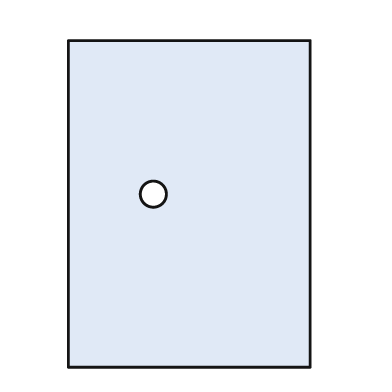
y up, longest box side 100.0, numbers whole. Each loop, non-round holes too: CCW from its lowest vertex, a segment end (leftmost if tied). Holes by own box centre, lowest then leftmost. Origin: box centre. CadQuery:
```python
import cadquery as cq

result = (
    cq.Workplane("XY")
    .moveTo(-37.0, -50.0)
    .lineTo(37.0, -50.0)
    .lineTo(37.0, 50.0)
    .lineTo(-37.0, 50.0)
    .close()
    .moveTo(-11.0, 3.0)
    .circle(4.0)
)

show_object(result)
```